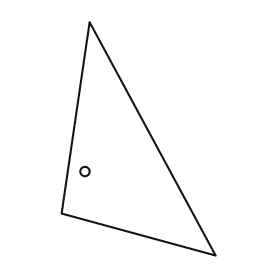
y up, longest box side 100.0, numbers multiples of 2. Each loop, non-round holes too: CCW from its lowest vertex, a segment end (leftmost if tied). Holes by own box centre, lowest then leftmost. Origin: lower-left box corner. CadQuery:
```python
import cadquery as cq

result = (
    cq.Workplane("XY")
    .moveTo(66.0, 0.0)
    .lineTo(12.0, 100.0)
    .lineTo(0.0, 18.0)
    .close()
    .moveTo(10.0, 36.0)
    .circle(2.0)
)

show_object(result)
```